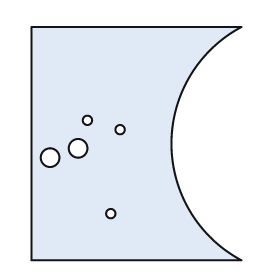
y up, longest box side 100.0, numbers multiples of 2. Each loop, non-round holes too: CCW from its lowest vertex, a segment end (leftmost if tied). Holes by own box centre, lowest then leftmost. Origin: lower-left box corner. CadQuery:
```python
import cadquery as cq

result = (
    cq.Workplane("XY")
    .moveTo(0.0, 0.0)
    .lineTo(90.0, 0.0)
    .threePointArc((60.0, 50.0), (90.0, 100.0))
    .lineTo(0.0, 100.0)
    .close()
    .moveTo(34.0, 20.0)
    .circle(2.0)
    .moveTo(8.0, 44.0)
    .circle(4.0)
    .moveTo(20.0, 48.0)
    .circle(4.0)
    .moveTo(38.0, 56.0)
    .circle(2.0)
    .moveTo(24.0, 60.0)
    .circle(2.0)
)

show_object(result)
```